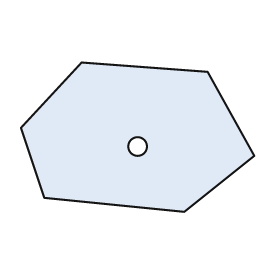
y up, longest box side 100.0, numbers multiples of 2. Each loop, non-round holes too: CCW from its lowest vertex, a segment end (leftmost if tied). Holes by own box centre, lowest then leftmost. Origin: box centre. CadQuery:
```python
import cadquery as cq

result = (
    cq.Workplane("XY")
    .moveTo(20.0, -32.0)
    .lineTo(50.0, -8.0)
    .lineTo(30.0, 28.0)
    .lineTo(-24.0, 32.0)
    .lineTo(-50.0, 4.0)
    .lineTo(-40.0, -26.0)
    .close()
    .moveTo(0.0, -4.0)
    .circle(4.0)
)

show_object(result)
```